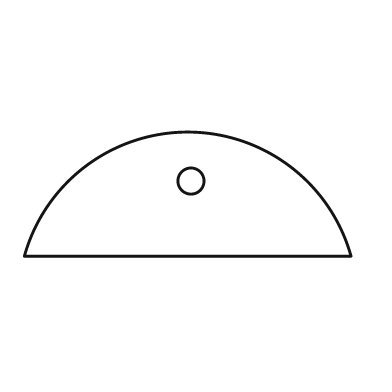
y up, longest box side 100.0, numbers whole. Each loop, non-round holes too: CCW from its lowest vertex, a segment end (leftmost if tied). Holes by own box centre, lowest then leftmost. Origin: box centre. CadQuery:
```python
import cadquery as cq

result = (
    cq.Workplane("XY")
    .moveTo(-50.0, -19.0)
    .lineTo(50.0, -19.0)
    .threePointArc((0.0, 19.0), (-50.0, -19.0))
    .close()
    .moveTo(1.0, 4.0)
    .circle(4.0)
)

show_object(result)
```